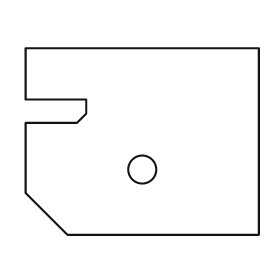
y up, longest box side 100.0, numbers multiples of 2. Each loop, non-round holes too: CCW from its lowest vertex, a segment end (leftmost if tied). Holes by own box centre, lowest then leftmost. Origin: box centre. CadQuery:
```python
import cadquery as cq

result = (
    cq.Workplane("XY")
    .moveTo(-32.0, -40.0)
    .lineTo(50.0, -40.0)
    .lineTo(50.0, 40.0)
    .lineTo(-50.0, 40.0)
    .lineTo(-50.0, 18.0)
    .lineTo(-24.0, 18.0)
    .lineTo(-24.0, 12.0)
    .lineTo(-28.0, 8.0)
    .lineTo(-50.0, 8.0)
    .lineTo(-50.0, -22.0)
    .close()
    .moveTo(0.0, -12.0)
    .circle(6.0)
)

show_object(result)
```